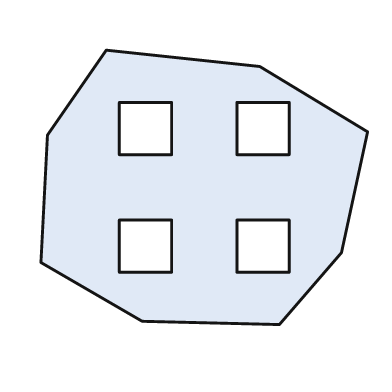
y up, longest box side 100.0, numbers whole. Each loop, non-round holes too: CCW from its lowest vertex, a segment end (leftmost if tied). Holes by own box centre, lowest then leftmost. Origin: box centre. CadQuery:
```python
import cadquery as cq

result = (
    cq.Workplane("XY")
    .moveTo(23.0, -42.0)
    .lineTo(42.0, -20.0)
    .lineTo(50.0, 17.0)
    .lineTo(17.0, 37.0)
    .lineTo(-30.0, 42.0)
    .lineTo(-48.0, 16.0)
    .lineTo(-50.0, -23.0)
    .lineTo(-19.0, -41.0)
    .close()
    .moveTo(-26.0, -26.0)
    .lineTo(-10.0, -26.0)
    .lineTo(-10.0, -10.0)
    .lineTo(-26.0, -10.0)
    .close()
    .moveTo(10.0, -26.0)
    .lineTo(26.0, -26.0)
    .lineTo(26.0, -10.0)
    .lineTo(10.0, -10.0)
    .close()
    .moveTo(-26.0, 10.0)
    .lineTo(-10.0, 10.0)
    .lineTo(-10.0, 26.0)
    .lineTo(-26.0, 26.0)
    .close()
    .moveTo(10.0, 10.0)
    .lineTo(26.0, 10.0)
    .lineTo(26.0, 26.0)
    .lineTo(10.0, 26.0)
    .close()
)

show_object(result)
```